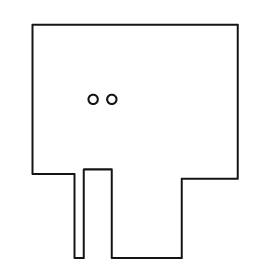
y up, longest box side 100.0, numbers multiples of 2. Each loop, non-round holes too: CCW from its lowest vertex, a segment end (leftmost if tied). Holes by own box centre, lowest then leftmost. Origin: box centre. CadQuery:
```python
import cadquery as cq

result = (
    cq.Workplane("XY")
    .moveTo(-26.0, -50.0)
    .lineTo(-22.0, -50.0)
    .lineTo(-22.0, -12.0)
    .lineTo(-10.0, -12.0)
    .lineTo(-10.0, -50.0)
    .lineTo(20.0, -50.0)
    .lineTo(20.0, -16.0)
    .lineTo(44.0, -16.0)
    .lineTo(44.0, 50.0)
    .lineTo(-44.0, 50.0)
    .lineTo(-44.0, -14.0)
    .lineTo(-26.0, -14.0)
    .close()
    .moveTo(-18.0, 18.0)
    .circle(2.0)
    .moveTo(-10.0, 18.0)
    .circle(2.0)
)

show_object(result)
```